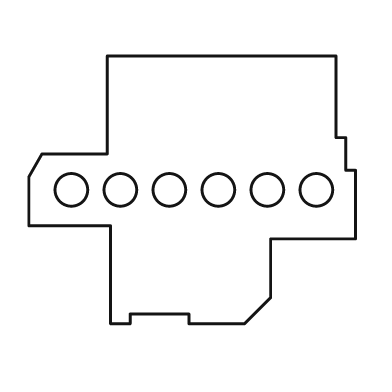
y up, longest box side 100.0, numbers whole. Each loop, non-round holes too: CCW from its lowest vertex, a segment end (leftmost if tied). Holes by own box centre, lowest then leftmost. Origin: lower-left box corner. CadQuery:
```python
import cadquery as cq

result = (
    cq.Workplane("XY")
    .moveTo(25.0, 0.0)
    .lineTo(31.0, 0.0)
    .lineTo(31.0, 3.0)
    .lineTo(49.0, 3.0)
    .lineTo(49.0, 0.0)
    .lineTo(66.0, 0.0)
    .lineTo(74.0, 8.0)
    .lineTo(74.0, 26.0)
    .lineTo(100.0, 26.0)
    .lineTo(100.0, 47.0)
    .lineTo(97.0, 47.0)
    .lineTo(97.0, 57.0)
    .lineTo(94.0, 57.0)
    .lineTo(94.0, 82.0)
    .lineTo(24.0, 82.0)
    .lineTo(24.0, 52.0)
    .lineTo(4.0, 52.0)
    .lineTo(0.0, 45.0)
    .lineTo(0.0, 30.0)
    .lineTo(25.0, 30.0)
    .close()
    .moveTo(13.0, 41.0)
    .circle(5.0)
    .moveTo(28.0, 41.0)
    .circle(5.0)
    .moveTo(43.0, 41.0)
    .circle(5.0)
    .moveTo(58.0, 41.0)
    .circle(5.0)
    .moveTo(73.0, 41.0)
    .circle(5.0)
    .moveTo(88.0, 41.0)
    .circle(5.0)
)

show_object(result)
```